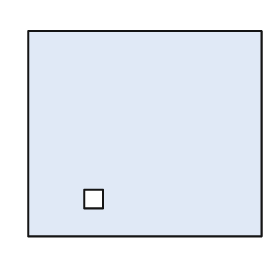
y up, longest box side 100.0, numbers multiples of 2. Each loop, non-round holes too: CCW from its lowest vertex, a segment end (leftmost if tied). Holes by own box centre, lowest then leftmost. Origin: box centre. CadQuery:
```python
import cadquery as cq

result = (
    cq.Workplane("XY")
    .moveTo(-50.0, -44.0)
    .lineTo(50.0, -44.0)
    .lineTo(50.0, 44.0)
    .lineTo(-50.0, 44.0)
    .close()
    .moveTo(-26.0, -32.0)
    .lineTo(-18.0, -32.0)
    .lineTo(-18.0, -24.0)
    .lineTo(-26.0, -24.0)
    .close()
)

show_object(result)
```